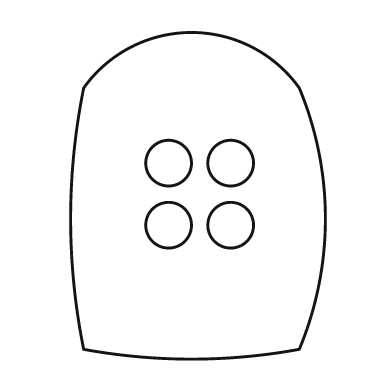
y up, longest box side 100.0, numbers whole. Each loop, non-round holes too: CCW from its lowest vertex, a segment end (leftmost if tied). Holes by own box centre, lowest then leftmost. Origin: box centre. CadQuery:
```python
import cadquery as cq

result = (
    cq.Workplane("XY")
    .moveTo(-35.0, -47.0)
    .threePointArc((-2.0, -50.0), (31.0, -47.0))
    .threePointArc((39.0, -7.0), (31.0, 33.0))
    .threePointArc((-2.0, 50.0), (-35.0, 33.0))
    .threePointArc((-39.0, -7.0), (-35.0, -47.0))
    .close()
    .moveTo(-9.0, -9.0)
    .circle(7.0)
    .moveTo(10.0, -9.0)
    .circle(7.0)
    .moveTo(-9.0, 10.0)
    .circle(7.0)
    .moveTo(10.0, 10.0)
    .circle(7.0)
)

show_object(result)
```